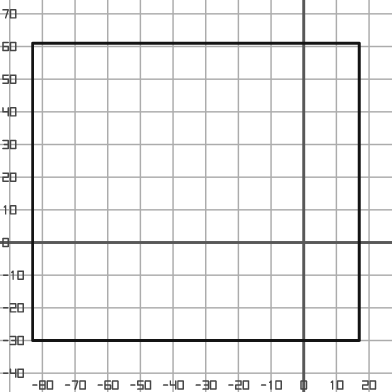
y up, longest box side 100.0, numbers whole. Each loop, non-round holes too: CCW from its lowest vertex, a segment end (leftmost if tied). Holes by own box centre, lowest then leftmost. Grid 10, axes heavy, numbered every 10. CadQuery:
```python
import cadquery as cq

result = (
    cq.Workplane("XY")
    .moveTo(-83.0, -30.0)
    .lineTo(17.0, -30.0)
    .lineTo(17.0, 61.0)
    .lineTo(-83.0, 61.0)
    .close()
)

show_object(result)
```